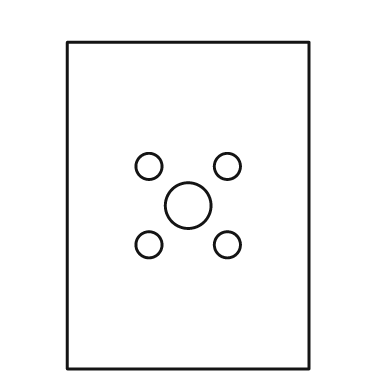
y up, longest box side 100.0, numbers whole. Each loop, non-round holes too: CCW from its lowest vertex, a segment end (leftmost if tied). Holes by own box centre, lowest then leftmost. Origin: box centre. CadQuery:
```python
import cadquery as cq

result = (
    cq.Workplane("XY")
    .moveTo(-37.0, -50.0)
    .lineTo(37.0, -50.0)
    .lineTo(37.0, 50.0)
    .lineTo(-37.0, 50.0)
    .close()
    .moveTo(-12.0, -12.0)
    .circle(4.0)
    .moveTo(12.0, -12.0)
    .circle(4.0)
    .moveTo(0.0, 0.0)
    .circle(7.0)
    .moveTo(-12.0, 12.0)
    .circle(4.0)
    .moveTo(12.0, 12.0)
    .circle(4.0)
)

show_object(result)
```